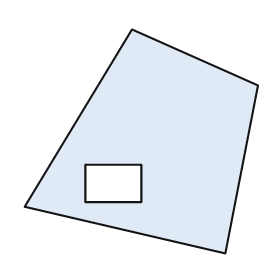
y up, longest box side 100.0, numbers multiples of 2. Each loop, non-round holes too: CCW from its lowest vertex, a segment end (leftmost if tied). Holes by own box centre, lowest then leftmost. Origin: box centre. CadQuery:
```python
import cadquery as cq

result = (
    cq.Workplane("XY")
    .moveTo(36.0, -48.0)
    .lineTo(50.0, 24.0)
    .lineTo(-4.0, 48.0)
    .lineTo(-50.0, -28.0)
    .close()
    .moveTo(-24.0, -26.0)
    .lineTo(0.0, -26.0)
    .lineTo(0.0, -10.0)
    .lineTo(-24.0, -10.0)
    .close()
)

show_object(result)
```